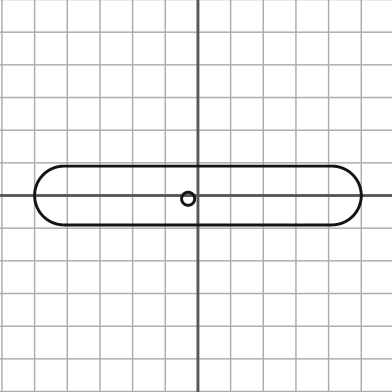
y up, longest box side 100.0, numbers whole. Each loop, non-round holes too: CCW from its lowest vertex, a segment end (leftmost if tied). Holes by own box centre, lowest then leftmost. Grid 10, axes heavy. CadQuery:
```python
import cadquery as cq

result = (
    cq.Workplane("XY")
    .moveTo(-41.0, -9.0)
    .lineTo(41.0, -9.0)
    .threePointArc((50.0, 0.0), (41.0, 9.0))
    .lineTo(-41.0, 9.0)
    .threePointArc((-50.0, 0.0), (-41.0, -9.0))
    .close()
    .moveTo(-3.0, -1.0)
    .circle(2.0)
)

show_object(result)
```